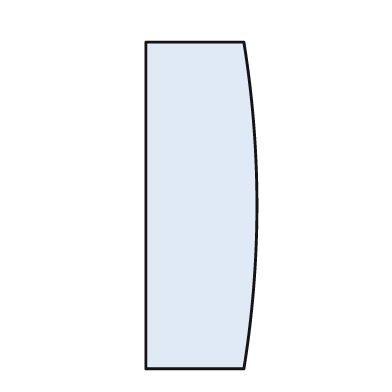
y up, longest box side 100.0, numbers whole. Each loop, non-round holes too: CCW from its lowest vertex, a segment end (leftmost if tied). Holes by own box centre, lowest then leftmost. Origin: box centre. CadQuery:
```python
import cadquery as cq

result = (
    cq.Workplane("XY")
    .moveTo(-17.0, -50.0)
    .lineTo(13.0, -50.0)
    .threePointArc((17.0, 0.0), (13.0, 50.0))
    .lineTo(-17.0, 50.0)
    .close()
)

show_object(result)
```